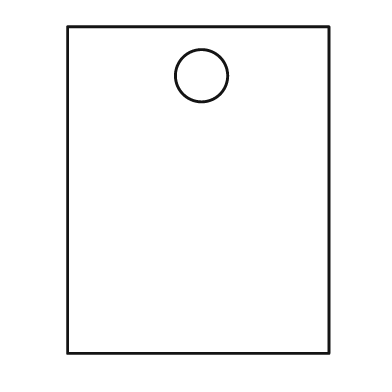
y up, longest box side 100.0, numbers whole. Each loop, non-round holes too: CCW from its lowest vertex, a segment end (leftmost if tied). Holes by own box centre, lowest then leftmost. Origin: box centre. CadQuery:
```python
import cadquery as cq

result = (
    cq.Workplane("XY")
    .moveTo(-40.0, -50.0)
    .lineTo(40.0, -50.0)
    .lineTo(40.0, 50.0)
    .lineTo(-40.0, 50.0)
    .close()
    .moveTo(1.0, 35.0)
    .circle(8.0)
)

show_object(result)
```